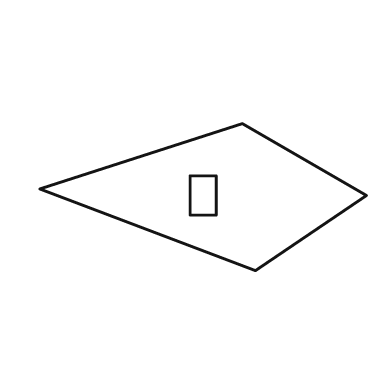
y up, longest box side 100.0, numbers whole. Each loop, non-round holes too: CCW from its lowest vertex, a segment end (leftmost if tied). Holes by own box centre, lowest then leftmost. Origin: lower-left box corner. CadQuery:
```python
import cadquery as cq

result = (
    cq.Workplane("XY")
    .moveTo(66.0, 0.0)
    .lineTo(100.0, 23.0)
    .lineTo(62.0, 45.0)
    .lineTo(0.0, 25.0)
    .close()
    .moveTo(46.0, 17.0)
    .lineTo(54.0, 17.0)
    .lineTo(54.0, 29.0)
    .lineTo(46.0, 29.0)
    .close()
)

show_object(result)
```